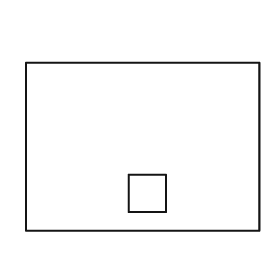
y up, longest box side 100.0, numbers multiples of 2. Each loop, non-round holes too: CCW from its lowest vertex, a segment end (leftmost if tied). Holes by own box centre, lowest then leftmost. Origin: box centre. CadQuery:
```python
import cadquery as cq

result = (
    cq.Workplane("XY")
    .moveTo(-50.0, -36.0)
    .lineTo(50.0, -36.0)
    .lineTo(50.0, 36.0)
    .lineTo(-50.0, 36.0)
    .close()
    .moveTo(-6.0, -28.0)
    .lineTo(10.0, -28.0)
    .lineTo(10.0, -12.0)
    .lineTo(-6.0, -12.0)
    .close()
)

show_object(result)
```